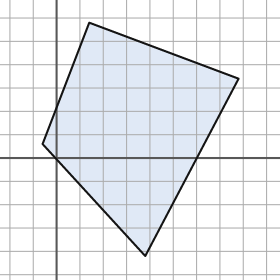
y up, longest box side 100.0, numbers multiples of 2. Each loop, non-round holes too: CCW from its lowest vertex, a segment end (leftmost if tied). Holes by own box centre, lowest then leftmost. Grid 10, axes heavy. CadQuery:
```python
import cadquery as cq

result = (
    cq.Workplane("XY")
    .moveTo(38.0, -42.0)
    .lineTo(78.0, 34.0)
    .lineTo(14.0, 58.0)
    .lineTo(-6.0, 6.0)
    .close()
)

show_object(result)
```